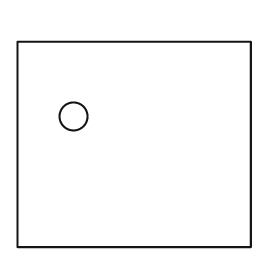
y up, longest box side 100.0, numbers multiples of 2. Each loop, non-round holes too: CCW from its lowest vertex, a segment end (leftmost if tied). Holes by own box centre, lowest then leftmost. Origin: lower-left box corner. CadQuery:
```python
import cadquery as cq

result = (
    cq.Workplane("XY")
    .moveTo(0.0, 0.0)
    .lineTo(100.0, 0.0)
    .lineTo(100.0, 88.0)
    .lineTo(0.0, 88.0)
    .close()
    .moveTo(24.0, 56.0)
    .circle(6.0)
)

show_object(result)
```